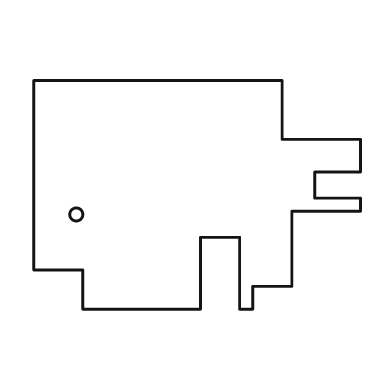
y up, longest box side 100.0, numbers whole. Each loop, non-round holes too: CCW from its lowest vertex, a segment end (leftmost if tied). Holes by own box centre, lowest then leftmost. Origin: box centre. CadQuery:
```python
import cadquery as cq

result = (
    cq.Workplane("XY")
    .moveTo(-35.0, -35.0)
    .lineTo(1.0, -35.0)
    .lineTo(1.0, -13.0)
    .lineTo(13.0, -13.0)
    .lineTo(13.0, -35.0)
    .lineTo(17.0, -35.0)
    .lineTo(17.0, -28.0)
    .lineTo(29.0, -28.0)
    .lineTo(29.0, -5.0)
    .lineTo(50.0, -5.0)
    .lineTo(50.0, -1.0)
    .lineTo(36.0, -1.0)
    .lineTo(36.0, 7.0)
    .lineTo(50.0, 7.0)
    .lineTo(50.0, 17.0)
    .lineTo(26.0, 17.0)
    .lineTo(26.0, 35.0)
    .lineTo(-50.0, 35.0)
    .lineTo(-50.0, -23.0)
    .lineTo(-35.0, -23.0)
    .close()
    .moveTo(-37.0, -6.0)
    .circle(2.0)
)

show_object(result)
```